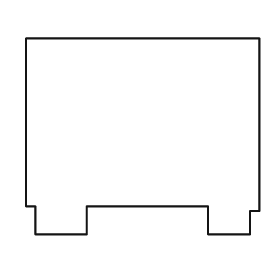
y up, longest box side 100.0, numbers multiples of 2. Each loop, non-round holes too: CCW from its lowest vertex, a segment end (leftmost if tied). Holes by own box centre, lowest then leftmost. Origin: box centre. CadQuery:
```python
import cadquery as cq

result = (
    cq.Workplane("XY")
    .moveTo(-46.0, -42.0)
    .lineTo(-24.0, -42.0)
    .lineTo(-24.0, -30.0)
    .lineTo(28.0, -30.0)
    .lineTo(28.0, -42.0)
    .lineTo(46.0, -42.0)
    .lineTo(46.0, -32.0)
    .lineTo(50.0, -32.0)
    .lineTo(50.0, 42.0)
    .lineTo(-50.0, 42.0)
    .lineTo(-50.0, -30.0)
    .lineTo(-46.0, -30.0)
    .close()
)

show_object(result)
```